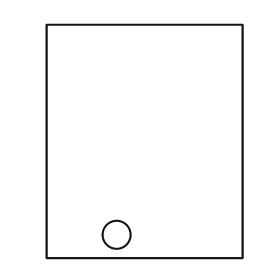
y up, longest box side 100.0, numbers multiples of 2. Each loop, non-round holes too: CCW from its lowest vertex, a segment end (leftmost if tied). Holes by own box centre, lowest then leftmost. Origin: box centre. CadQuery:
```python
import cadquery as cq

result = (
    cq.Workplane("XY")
    .moveTo(-42.0, -50.0)
    .lineTo(42.0, -50.0)
    .lineTo(42.0, 50.0)
    .lineTo(-42.0, 50.0)
    .close()
    .moveTo(-12.0, -40.0)
    .circle(6.0)
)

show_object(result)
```